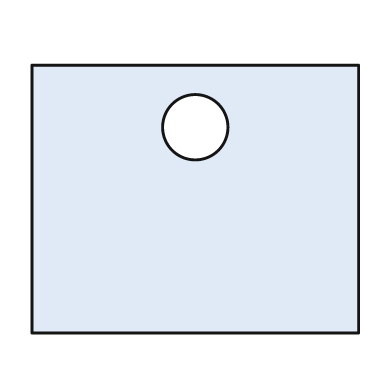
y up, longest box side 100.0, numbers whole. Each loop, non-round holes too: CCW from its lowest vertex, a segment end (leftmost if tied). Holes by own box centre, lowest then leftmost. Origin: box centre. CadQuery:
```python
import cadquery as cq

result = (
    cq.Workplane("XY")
    .moveTo(-50.0, -41.0)
    .lineTo(50.0, -41.0)
    .lineTo(50.0, 41.0)
    .lineTo(-50.0, 41.0)
    .close()
    .moveTo(0.0, 22.0)
    .circle(10.0)
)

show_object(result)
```